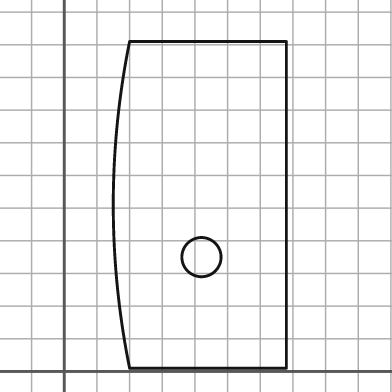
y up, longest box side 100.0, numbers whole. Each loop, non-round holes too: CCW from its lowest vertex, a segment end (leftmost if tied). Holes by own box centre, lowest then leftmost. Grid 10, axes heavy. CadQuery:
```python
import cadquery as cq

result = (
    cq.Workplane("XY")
    .moveTo(20.0, 1.0)
    .lineTo(68.0, 1.0)
    .lineTo(68.0, 101.0)
    .lineTo(20.0, 101.0)
    .threePointArc((15.0, 51.0), (20.0, 1.0))
    .close()
    .moveTo(42.0, 35.0)
    .circle(6.0)
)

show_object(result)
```